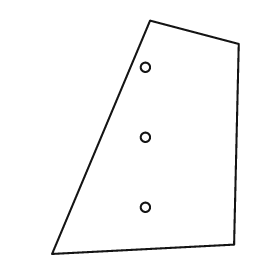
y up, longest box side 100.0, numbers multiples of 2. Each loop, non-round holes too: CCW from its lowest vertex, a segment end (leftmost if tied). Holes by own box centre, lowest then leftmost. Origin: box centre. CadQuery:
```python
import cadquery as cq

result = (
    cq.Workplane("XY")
    .moveTo(-40.0, -50.0)
    .lineTo(38.0, -46.0)
    .lineTo(40.0, 40.0)
    .lineTo(2.0, 50.0)
    .close()
    .moveTo(0.0, -30.0)
    .circle(2.0)
    .moveTo(0.0, 0.0)
    .circle(2.0)
    .moveTo(0.0, 30.0)
    .circle(2.0)
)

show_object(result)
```